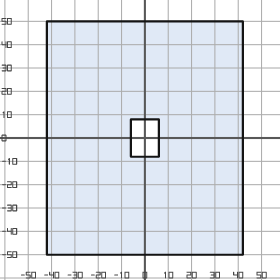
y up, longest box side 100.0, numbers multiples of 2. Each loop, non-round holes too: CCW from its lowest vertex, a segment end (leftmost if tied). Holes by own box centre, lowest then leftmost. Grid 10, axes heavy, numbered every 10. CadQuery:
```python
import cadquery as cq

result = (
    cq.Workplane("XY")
    .moveTo(-42.0, -50.0)
    .lineTo(42.0, -50.0)
    .lineTo(42.0, 50.0)
    .lineTo(-42.0, 50.0)
    .close()
    .moveTo(-6.0, -8.0)
    .lineTo(6.0, -8.0)
    .lineTo(6.0, 8.0)
    .lineTo(-6.0, 8.0)
    .close()
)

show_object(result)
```